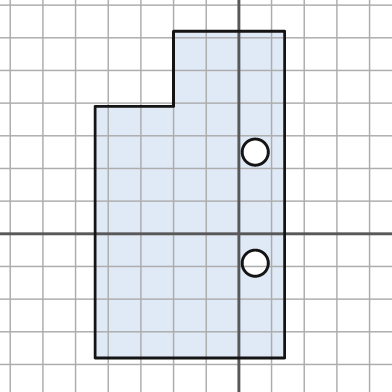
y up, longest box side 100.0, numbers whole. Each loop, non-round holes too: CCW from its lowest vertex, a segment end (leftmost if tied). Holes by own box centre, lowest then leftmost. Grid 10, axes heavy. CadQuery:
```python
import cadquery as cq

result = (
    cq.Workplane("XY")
    .moveTo(-44.0, -38.0)
    .lineTo(14.0, -38.0)
    .lineTo(14.0, 62.0)
    .lineTo(-20.0, 62.0)
    .lineTo(-20.0, 39.0)
    .lineTo(-44.0, 39.0)
    .close()
    .moveTo(5.0, -9.0)
    .circle(4.0)
    .moveTo(5.0, 25.0)
    .circle(4.0)
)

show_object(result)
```